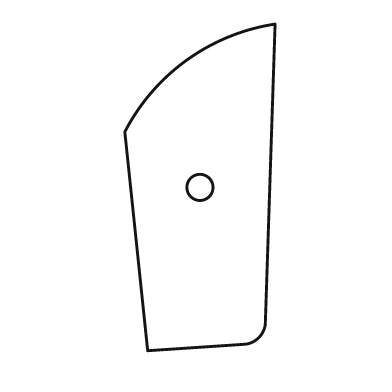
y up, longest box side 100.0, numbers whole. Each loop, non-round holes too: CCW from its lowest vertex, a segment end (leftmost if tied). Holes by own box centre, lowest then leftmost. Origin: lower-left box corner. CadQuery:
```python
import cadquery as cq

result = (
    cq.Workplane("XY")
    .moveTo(7.0, 0.0)
    .lineTo(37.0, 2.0)
    .threePointArc((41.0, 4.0), (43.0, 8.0))
    .lineTo(46.0, 100.0)
    .threePointArc((19.0, 89.0), (0.0, 67.0))
    .close()
    .moveTo(23.0, 50.0)
    .circle(4.0)
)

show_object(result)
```